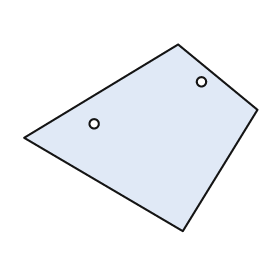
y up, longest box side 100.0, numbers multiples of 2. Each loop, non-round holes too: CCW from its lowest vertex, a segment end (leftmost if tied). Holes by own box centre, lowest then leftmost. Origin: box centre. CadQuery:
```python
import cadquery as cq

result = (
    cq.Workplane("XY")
    .moveTo(18.0, -40.0)
    .lineTo(50.0, 12.0)
    .lineTo(16.0, 40.0)
    .lineTo(-50.0, 0.0)
    .close()
    .moveTo(-20.0, 6.0)
    .circle(2.0)
    .moveTo(26.0, 24.0)
    .circle(2.0)
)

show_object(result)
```